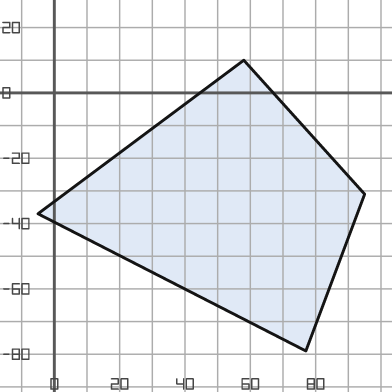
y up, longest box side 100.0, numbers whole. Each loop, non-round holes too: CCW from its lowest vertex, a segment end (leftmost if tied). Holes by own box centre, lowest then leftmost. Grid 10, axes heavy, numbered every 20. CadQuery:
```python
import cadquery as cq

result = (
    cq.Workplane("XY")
    .moveTo(77.0, -79.0)
    .lineTo(95.0, -31.0)
    .lineTo(58.0, 10.0)
    .lineTo(-5.0, -37.0)
    .close()
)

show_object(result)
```